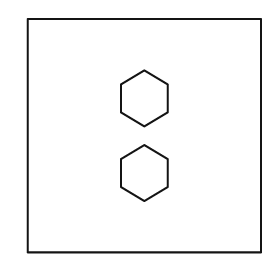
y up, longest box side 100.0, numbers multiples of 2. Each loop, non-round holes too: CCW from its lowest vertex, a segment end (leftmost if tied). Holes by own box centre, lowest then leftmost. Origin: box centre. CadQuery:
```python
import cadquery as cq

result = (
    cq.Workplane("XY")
    .moveTo(-50.0, -50.0)
    .lineTo(50.0, -50.0)
    .lineTo(50.0, 50.0)
    .lineTo(-50.0, 50.0)
    .close()
    .moveTo(0.0, -28.0)
    .lineTo(10.0, -22.0)
    .lineTo(10.0, -10.0)
    .lineTo(0.0, -4.0)
    .lineTo(-10.0, -10.0)
    .lineTo(-10.0, -22.0)
    .close()
    .moveTo(0.0, 4.0)
    .lineTo(10.0, 10.0)
    .lineTo(10.0, 22.0)
    .lineTo(0.0, 28.0)
    .lineTo(-10.0, 22.0)
    .lineTo(-10.0, 10.0)
    .close()
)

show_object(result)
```